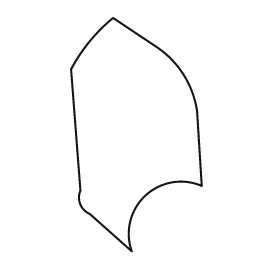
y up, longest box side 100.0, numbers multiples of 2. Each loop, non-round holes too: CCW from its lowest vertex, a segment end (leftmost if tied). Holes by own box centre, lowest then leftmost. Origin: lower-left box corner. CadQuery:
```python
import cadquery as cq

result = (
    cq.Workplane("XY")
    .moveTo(26.0, 0.0)
    .threePointArc((32.0, 24.0), (56.0, 28.0))
    .lineTo(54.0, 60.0)
    .threePointArc((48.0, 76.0), (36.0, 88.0))
    .lineTo(18.0, 100.0)
    .threePointArc((8.0, 90.0), (0.0, 78.0))
    .lineTo(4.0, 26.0)
    .threePointArc((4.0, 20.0), (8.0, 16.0))
    .close()
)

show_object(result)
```